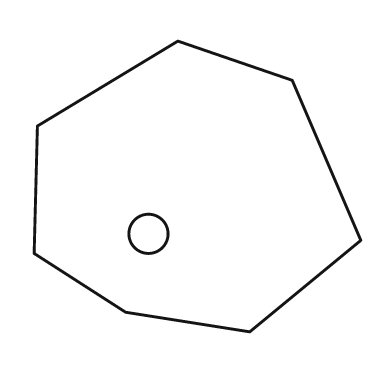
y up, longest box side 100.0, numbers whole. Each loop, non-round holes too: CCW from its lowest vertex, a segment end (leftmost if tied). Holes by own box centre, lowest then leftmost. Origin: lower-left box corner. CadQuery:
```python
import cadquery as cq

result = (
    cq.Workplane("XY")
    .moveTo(66.0, 0.0)
    .lineTo(100.0, 28.0)
    .lineTo(79.0, 77.0)
    .lineTo(44.0, 89.0)
    .lineTo(1.0, 63.0)
    .lineTo(0.0, 24.0)
    .lineTo(28.0, 6.0)
    .close()
    .moveTo(35.0, 30.0)
    .circle(6.0)
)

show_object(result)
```